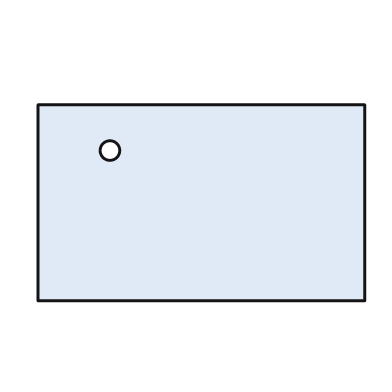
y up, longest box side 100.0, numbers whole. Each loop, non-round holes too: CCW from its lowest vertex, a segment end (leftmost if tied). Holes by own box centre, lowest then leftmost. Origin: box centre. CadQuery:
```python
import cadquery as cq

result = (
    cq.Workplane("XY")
    .moveTo(-50.0, -30.0)
    .lineTo(50.0, -30.0)
    .lineTo(50.0, 30.0)
    .lineTo(-50.0, 30.0)
    .close()
    .moveTo(-28.0, 16.0)
    .circle(3.0)
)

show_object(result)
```